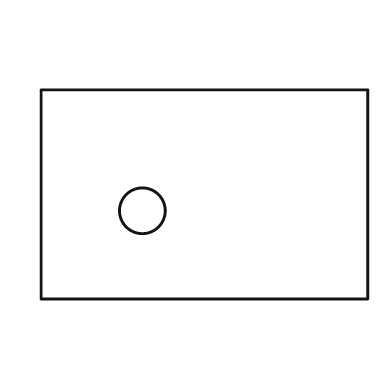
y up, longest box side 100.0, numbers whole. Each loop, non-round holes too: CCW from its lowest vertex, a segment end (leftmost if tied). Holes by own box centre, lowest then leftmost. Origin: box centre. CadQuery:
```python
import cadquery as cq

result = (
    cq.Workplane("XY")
    .moveTo(-50.0, -32.0)
    .lineTo(50.0, -32.0)
    .lineTo(50.0, 32.0)
    .lineTo(-50.0, 32.0)
    .close()
    .moveTo(-19.0, -5.0)
    .circle(7.0)
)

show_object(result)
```